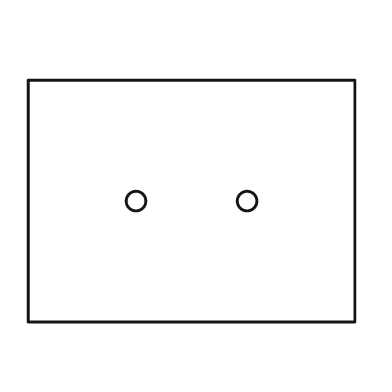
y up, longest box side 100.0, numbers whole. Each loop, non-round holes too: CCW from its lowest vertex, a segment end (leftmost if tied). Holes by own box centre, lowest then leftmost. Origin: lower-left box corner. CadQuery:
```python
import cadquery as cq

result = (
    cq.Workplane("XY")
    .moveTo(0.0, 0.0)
    .lineTo(100.0, 0.0)
    .lineTo(100.0, 74.0)
    .lineTo(0.0, 74.0)
    .close()
    .moveTo(33.0, 37.0)
    .circle(3.0)
    .moveTo(67.0, 37.0)
    .circle(3.0)
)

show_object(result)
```